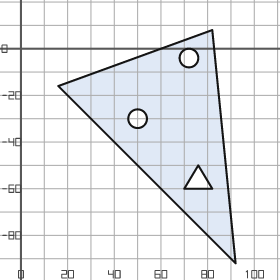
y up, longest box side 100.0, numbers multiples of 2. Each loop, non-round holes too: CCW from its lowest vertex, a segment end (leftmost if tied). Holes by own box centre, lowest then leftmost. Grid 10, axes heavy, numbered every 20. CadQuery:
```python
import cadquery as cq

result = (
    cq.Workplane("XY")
    .moveTo(92.0, -92.0)
    .lineTo(82.0, 8.0)
    .lineTo(16.0, -16.0)
    .close()
    .moveTo(70.0, -60.0)
    .lineTo(82.0, -60.0)
    .lineTo(76.0, -50.0)
    .close()
    .moveTo(50.0, -30.0)
    .circle(4.0)
    .moveTo(72.0, -4.0)
    .circle(4.0)
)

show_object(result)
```